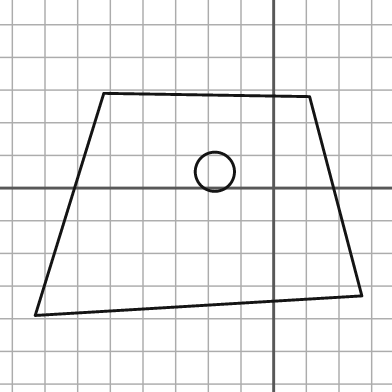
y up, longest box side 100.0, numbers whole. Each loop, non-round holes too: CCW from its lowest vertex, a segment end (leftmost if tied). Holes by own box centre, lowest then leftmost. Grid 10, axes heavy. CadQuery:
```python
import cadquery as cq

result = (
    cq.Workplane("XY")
    .moveTo(-73.0, -39.0)
    .lineTo(27.0, -33.0)
    .lineTo(11.0, 28.0)
    .lineTo(-52.0, 29.0)
    .close()
    .moveTo(-18.0, 5.0)
    .circle(6.0)
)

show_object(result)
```